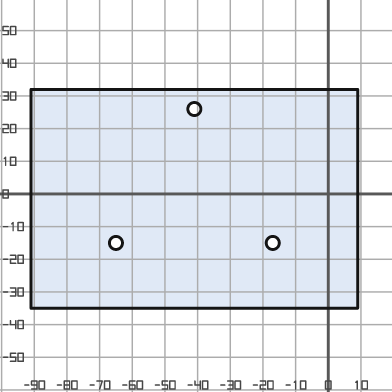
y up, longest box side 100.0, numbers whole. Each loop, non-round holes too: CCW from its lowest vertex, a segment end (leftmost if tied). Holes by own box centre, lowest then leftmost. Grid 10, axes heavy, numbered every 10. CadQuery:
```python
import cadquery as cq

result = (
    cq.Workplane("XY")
    .moveTo(-91.0, -35.0)
    .lineTo(9.0, -35.0)
    .lineTo(9.0, 32.0)
    .lineTo(-91.0, 32.0)
    .close()
    .moveTo(-65.0, -15.0)
    .circle(2.0)
    .moveTo(-17.0, -15.0)
    .circle(2.0)
    .moveTo(-41.0, 26.0)
    .circle(2.0)
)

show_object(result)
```